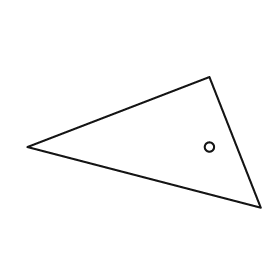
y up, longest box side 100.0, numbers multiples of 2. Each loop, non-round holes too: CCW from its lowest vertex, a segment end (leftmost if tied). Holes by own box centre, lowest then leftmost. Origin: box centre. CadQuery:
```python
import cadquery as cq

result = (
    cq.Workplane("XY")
    .moveTo(50.0, -28.0)
    .lineTo(28.0, 28.0)
    .lineTo(-50.0, -2.0)
    .close()
    .moveTo(28.0, -2.0)
    .circle(2.0)
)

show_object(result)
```